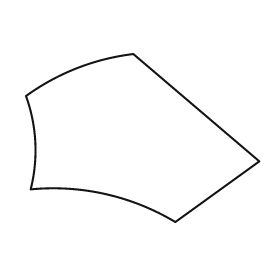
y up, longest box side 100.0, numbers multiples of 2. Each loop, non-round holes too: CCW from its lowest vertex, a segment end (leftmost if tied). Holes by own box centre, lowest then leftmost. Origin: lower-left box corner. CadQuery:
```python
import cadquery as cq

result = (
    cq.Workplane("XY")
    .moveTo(64.0, 0.0)
    .lineTo(100.0, 26.0)
    .lineTo(46.0, 72.0)
    .threePointArc((22.0, 66.0), (0.0, 54.0))
    .threePointArc((4.0, 34.0), (2.0, 14.0))
    .threePointArc((34.0, 12.0), (64.0, 0.0))
    .close()
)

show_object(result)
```